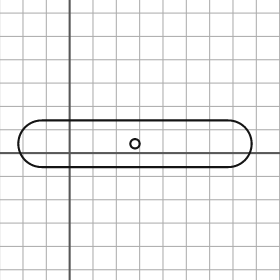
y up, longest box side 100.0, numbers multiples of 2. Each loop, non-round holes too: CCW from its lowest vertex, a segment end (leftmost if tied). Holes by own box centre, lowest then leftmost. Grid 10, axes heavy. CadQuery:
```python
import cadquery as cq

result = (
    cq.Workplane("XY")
    .moveTo(-12.0, -6.0)
    .lineTo(68.0, -6.0)
    .threePointArc((78.0, 4.0), (68.0, 14.0))
    .lineTo(-12.0, 14.0)
    .threePointArc((-22.0, 4.0), (-12.0, -6.0))
    .close()
    .moveTo(28.0, 4.0)
    .circle(2.0)
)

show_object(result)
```